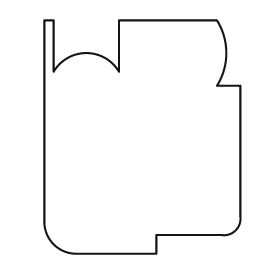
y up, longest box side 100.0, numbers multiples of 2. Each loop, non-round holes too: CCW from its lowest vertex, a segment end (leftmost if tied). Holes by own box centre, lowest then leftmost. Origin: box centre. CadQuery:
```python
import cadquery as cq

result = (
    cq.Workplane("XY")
    .moveTo(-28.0, -50.0)
    .lineTo(6.0, -50.0)
    .lineTo(6.0, -42.0)
    .lineTo(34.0, -42.0)
    .threePointArc((40.0, -40.0), (42.0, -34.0))
    .lineTo(42.0, 22.0)
    .lineTo(32.0, 22.0)
    .threePointArc((36.0, 36.0), (32.0, 50.0))
    .lineTo(-10.0, 50.0)
    .lineTo(-10.0, 28.0)
    .threePointArc((-24.0, 36.0), (-38.0, 28.0))
    .lineTo(-38.0, 50.0)
    .lineTo(-42.0, 50.0)
    .lineTo(-42.0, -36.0)
    .threePointArc((-38.0, -46.0), (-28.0, -50.0))
    .close()
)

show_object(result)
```